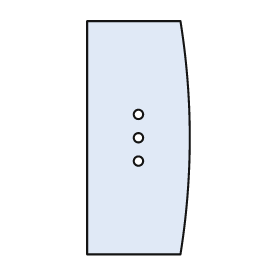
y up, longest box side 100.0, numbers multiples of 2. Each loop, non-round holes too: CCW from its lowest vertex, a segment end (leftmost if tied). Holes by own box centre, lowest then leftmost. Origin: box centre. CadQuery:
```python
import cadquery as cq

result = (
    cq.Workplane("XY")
    .moveTo(-22.0, -50.0)
    .lineTo(18.0, -50.0)
    .threePointArc((22.0, 0.0), (18.0, 50.0))
    .lineTo(-22.0, 50.0)
    .close()
    .moveTo(0.0, -10.0)
    .circle(2.0)
    .moveTo(0.0, 0.0)
    .circle(2.0)
    .moveTo(0.0, 10.0)
    .circle(2.0)
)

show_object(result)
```